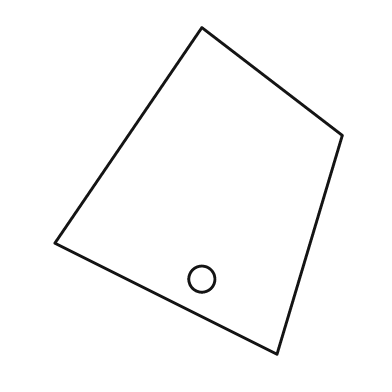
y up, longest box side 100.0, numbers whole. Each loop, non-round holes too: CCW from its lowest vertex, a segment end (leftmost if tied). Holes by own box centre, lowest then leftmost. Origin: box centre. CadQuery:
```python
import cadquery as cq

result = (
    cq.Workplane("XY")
    .moveTo(24.0, -50.0)
    .lineTo(44.0, 17.0)
    .lineTo(1.0, 50.0)
    .lineTo(-44.0, -16.0)
    .close()
    .moveTo(1.0, -27.0)
    .circle(4.0)
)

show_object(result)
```